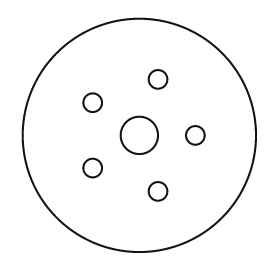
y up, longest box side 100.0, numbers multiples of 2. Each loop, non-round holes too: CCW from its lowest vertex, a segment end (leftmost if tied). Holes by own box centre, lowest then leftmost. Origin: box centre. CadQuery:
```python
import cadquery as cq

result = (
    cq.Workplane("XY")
    .moveTo(0.0, 0.0)
    .circle(50.0)
    .moveTo(8.0, -24.0)
    .circle(4.0)
    .moveTo(-20.0, -14.0)
    .circle(4.0)
    .moveTo(0.0, 0.0)
    .circle(8.0)
    .moveTo(24.0, 0.0)
    .circle(4.0)
    .moveTo(-20.0, 14.0)
    .circle(4.0)
    .moveTo(8.0, 24.0)
    .circle(4.0)
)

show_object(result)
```